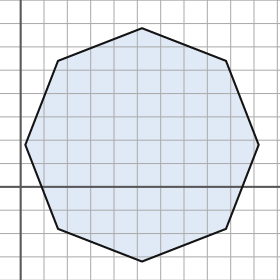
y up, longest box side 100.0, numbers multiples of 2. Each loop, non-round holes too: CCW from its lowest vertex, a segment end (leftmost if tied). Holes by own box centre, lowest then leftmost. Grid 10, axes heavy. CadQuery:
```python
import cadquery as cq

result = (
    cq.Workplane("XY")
    .moveTo(52.0, -32.0)
    .lineTo(88.0, -18.0)
    .lineTo(102.0, 18.0)
    .lineTo(88.0, 54.0)
    .lineTo(52.0, 68.0)
    .lineTo(16.0, 54.0)
    .lineTo(2.0, 18.0)
    .lineTo(16.0, -18.0)
    .close()
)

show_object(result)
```